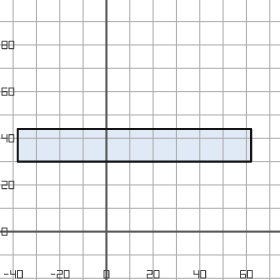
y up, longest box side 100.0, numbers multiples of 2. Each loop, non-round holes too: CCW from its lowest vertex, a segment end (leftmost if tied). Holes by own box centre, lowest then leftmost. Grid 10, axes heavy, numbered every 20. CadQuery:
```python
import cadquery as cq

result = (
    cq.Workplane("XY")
    .moveTo(-38.0, 30.0)
    .lineTo(62.0, 30.0)
    .lineTo(62.0, 44.0)
    .lineTo(-38.0, 44.0)
    .close()
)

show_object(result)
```